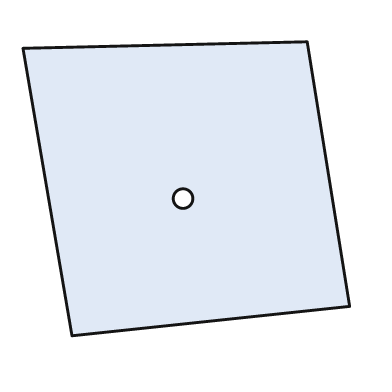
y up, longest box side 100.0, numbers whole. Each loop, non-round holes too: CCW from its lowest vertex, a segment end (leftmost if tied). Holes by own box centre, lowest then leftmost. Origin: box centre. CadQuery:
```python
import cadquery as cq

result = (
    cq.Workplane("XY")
    .moveTo(-35.0, -45.0)
    .lineTo(50.0, -36.0)
    .lineTo(37.0, 45.0)
    .lineTo(-50.0, 43.0)
    .close()
    .moveTo(-1.0, -3.0)
    .circle(3.0)
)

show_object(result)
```